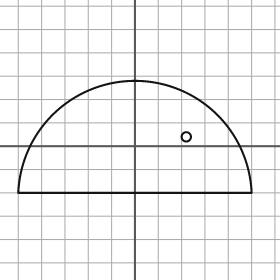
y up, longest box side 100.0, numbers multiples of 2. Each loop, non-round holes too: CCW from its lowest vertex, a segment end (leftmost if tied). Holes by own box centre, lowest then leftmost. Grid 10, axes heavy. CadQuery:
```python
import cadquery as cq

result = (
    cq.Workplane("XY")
    .moveTo(-50.0, -20.0)
    .lineTo(50.0, -20.0)
    .threePointArc((0.0, 28.0), (-50.0, -20.0))
    .close()
    .moveTo(22.0, 4.0)
    .circle(2.0)
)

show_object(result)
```